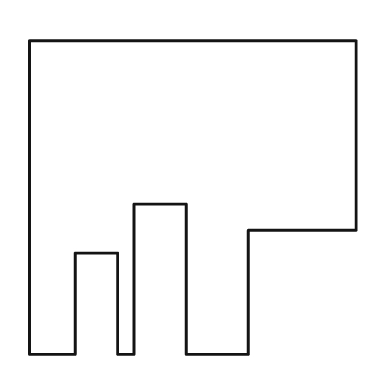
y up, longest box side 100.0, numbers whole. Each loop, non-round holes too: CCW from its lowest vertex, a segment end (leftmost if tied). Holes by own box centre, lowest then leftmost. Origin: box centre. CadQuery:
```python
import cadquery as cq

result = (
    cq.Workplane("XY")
    .moveTo(-50.0, -48.0)
    .lineTo(-36.0, -48.0)
    .lineTo(-36.0, -17.0)
    .lineTo(-23.0, -17.0)
    .lineTo(-23.0, -48.0)
    .lineTo(-18.0, -48.0)
    .lineTo(-18.0, -2.0)
    .lineTo(-2.0, -2.0)
    .lineTo(-2.0, -48.0)
    .lineTo(17.0, -48.0)
    .lineTo(17.0, -10.0)
    .lineTo(50.0, -10.0)
    .lineTo(50.0, 48.0)
    .lineTo(-50.0, 48.0)
    .close()
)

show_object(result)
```